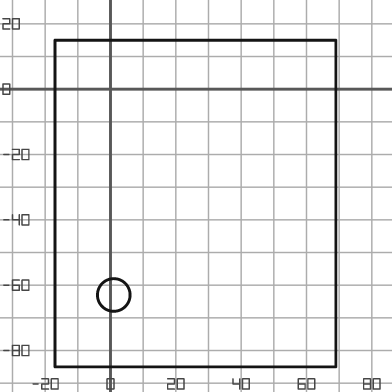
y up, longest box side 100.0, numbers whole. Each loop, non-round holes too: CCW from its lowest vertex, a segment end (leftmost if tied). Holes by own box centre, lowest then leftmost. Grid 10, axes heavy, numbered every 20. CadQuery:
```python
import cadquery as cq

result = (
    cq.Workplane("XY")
    .moveTo(-17.0, -85.0)
    .lineTo(69.0, -85.0)
    .lineTo(69.0, 15.0)
    .lineTo(-17.0, 15.0)
    .close()
    .moveTo(1.0, -63.0)
    .circle(5.0)
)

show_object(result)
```